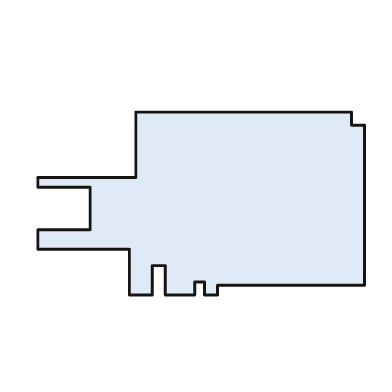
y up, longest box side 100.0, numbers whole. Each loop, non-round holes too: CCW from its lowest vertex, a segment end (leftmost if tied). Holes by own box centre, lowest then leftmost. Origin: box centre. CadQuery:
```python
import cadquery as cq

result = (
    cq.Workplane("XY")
    .moveTo(-22.0, -28.0)
    .lineTo(-15.0, -28.0)
    .lineTo(-15.0, -19.0)
    .lineTo(-11.0, -19.0)
    .lineTo(-11.0, -28.0)
    .lineTo(-2.0, -28.0)
    .lineTo(-2.0, -24.0)
    .lineTo(1.0, -24.0)
    .lineTo(1.0, -28.0)
    .lineTo(5.0, -28.0)
    .lineTo(5.0, -25.0)
    .lineTo(50.0, -25.0)
    .lineTo(50.0, 24.0)
    .lineTo(46.0, 24.0)
    .lineTo(46.0, 28.0)
    .lineTo(-20.0, 28.0)
    .lineTo(-20.0, 8.0)
    .lineTo(-50.0, 8.0)
    .lineTo(-50.0, 5.0)
    .lineTo(-34.0, 5.0)
    .lineTo(-34.0, -8.0)
    .lineTo(-50.0, -8.0)
    .lineTo(-50.0, -14.0)
    .lineTo(-22.0, -14.0)
    .close()
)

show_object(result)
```